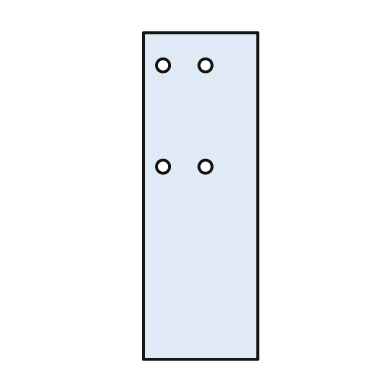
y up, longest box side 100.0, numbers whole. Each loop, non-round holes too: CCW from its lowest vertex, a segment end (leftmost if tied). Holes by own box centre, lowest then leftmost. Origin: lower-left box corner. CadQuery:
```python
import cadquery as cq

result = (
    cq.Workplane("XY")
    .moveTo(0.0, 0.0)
    .lineTo(35.0, 0.0)
    .lineTo(35.0, 100.0)
    .lineTo(0.0, 100.0)
    .close()
    .moveTo(6.0, 59.0)
    .circle(2.0)
    .moveTo(19.0, 59.0)
    .circle(2.0)
    .moveTo(6.0, 90.0)
    .circle(2.0)
    .moveTo(19.0, 90.0)
    .circle(2.0)
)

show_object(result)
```